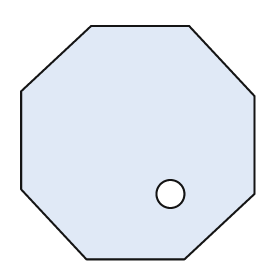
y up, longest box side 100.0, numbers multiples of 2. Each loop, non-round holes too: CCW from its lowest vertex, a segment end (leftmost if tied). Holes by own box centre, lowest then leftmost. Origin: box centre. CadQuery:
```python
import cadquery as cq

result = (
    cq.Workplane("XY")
    .moveTo(-22.0, -50.0)
    .lineTo(20.0, -50.0)
    .lineTo(50.0, -22.0)
    .lineTo(50.0, 20.0)
    .lineTo(22.0, 50.0)
    .lineTo(-20.0, 50.0)
    .lineTo(-50.0, 22.0)
    .lineTo(-50.0, -20.0)
    .close()
    .moveTo(14.0, -22.0)
    .circle(6.0)
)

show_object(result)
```